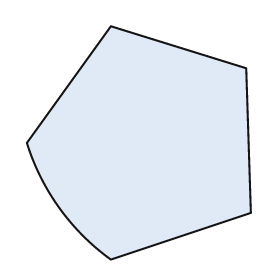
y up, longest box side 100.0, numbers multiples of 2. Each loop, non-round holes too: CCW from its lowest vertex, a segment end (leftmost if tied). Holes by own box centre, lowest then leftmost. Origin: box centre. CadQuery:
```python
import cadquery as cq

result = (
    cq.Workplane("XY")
    .moveTo(-12.0, -50.0)
    .lineTo(48.0, -30.0)
    .lineTo(46.0, 32.0)
    .lineTo(-12.0, 50.0)
    .lineTo(-48.0, 0.0)
    .threePointArc((-34.0, -28.0), (-12.0, -50.0))
    .close()
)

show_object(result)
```